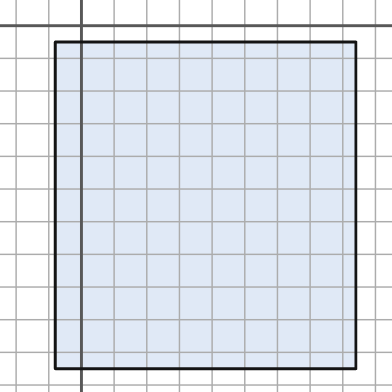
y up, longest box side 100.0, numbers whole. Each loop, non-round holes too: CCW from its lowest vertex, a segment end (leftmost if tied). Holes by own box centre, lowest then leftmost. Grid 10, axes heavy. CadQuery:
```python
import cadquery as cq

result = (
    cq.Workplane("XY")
    .moveTo(-8.0, -105.0)
    .lineTo(84.0, -105.0)
    .lineTo(84.0, -5.0)
    .lineTo(-8.0, -5.0)
    .close()
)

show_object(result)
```